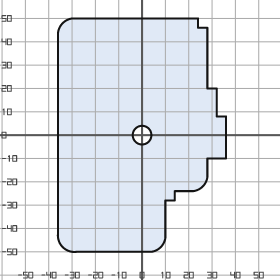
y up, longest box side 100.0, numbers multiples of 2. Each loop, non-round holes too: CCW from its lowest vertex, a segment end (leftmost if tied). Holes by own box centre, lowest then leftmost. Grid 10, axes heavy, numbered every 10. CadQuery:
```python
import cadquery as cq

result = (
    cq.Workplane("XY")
    .moveTo(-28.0, -50.0)
    .lineTo(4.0, -50.0)
    .threePointArc((8.0, -48.0), (10.0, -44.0))
    .lineTo(10.0, -28.0)
    .lineTo(14.0, -28.0)
    .lineTo(14.0, -24.0)
    .lineTo(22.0, -24.0)
    .threePointArc((26.0, -22.0), (28.0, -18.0))
    .lineTo(28.0, -10.0)
    .lineTo(36.0, -10.0)
    .lineTo(36.0, 8.0)
    .lineTo(32.0, 8.0)
    .lineTo(32.0, 20.0)
    .lineTo(28.0, 20.0)
    .lineTo(28.0, 46.0)
    .lineTo(24.0, 46.0)
    .lineTo(24.0, 50.0)
    .lineTo(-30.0, 50.0)
    .threePointArc((-34.0, 48.0), (-36.0, 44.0))
    .lineTo(-36.0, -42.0)
    .threePointArc((-34.0, -48.0), (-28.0, -50.0))
    .close()
    .moveTo(0.0, 0.0)
    .circle(4.0)
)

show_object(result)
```